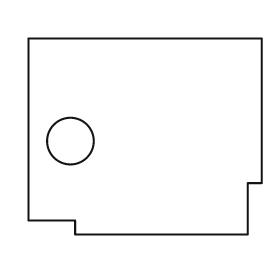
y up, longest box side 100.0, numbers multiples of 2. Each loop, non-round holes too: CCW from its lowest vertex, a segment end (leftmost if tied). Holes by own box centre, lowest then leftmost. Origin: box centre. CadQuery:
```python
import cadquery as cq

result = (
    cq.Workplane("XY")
    .moveTo(-30.0, -42.0)
    .lineTo(44.0, -42.0)
    .lineTo(44.0, -20.0)
    .lineTo(50.0, -20.0)
    .lineTo(50.0, 42.0)
    .lineTo(-50.0, 42.0)
    .lineTo(-50.0, -36.0)
    .lineTo(-30.0, -36.0)
    .close()
    .moveTo(-32.0, -2.0)
    .circle(10.0)
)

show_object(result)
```